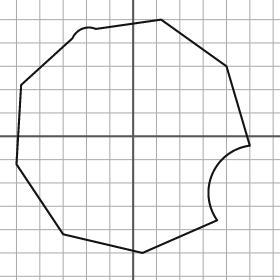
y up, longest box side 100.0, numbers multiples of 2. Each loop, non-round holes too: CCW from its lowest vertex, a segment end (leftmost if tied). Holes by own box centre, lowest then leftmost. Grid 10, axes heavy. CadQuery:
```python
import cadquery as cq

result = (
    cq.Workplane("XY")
    .moveTo(4.0, -50.0)
    .lineTo(36.0, -36.0)
    .threePointArc((34.0, -16.0), (50.0, -4.0))
    .lineTo(40.0, 30.0)
    .lineTo(12.0, 50.0)
    .lineTo(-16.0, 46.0)
    .threePointArc((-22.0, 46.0), (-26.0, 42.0))
    .lineTo(-48.0, 22.0)
    .lineTo(-50.0, -12.0)
    .lineTo(-30.0, -42.0)
    .close()
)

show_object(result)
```